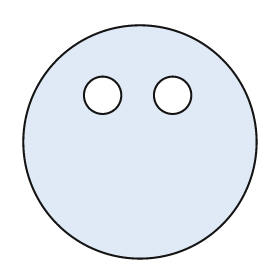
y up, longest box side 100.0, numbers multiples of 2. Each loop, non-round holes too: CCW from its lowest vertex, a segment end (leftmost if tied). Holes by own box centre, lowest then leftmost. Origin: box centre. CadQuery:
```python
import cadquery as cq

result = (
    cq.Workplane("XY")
    .moveTo(0.0, 0.0)
    .circle(50.0)
    .moveTo(-16.0, 20.0)
    .circle(8.0)
    .moveTo(14.0, 20.0)
    .circle(8.0)
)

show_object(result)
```